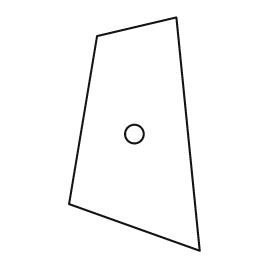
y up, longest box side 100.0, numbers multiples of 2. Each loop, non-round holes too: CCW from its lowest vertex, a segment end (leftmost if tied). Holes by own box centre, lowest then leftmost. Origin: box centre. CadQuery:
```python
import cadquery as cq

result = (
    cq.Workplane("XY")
    .moveTo(28.0, -50.0)
    .lineTo(18.0, 50.0)
    .lineTo(-16.0, 42.0)
    .lineTo(-28.0, -30.0)
    .close()
    .moveTo(0.0, 0.0)
    .circle(4.0)
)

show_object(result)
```